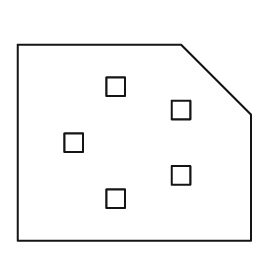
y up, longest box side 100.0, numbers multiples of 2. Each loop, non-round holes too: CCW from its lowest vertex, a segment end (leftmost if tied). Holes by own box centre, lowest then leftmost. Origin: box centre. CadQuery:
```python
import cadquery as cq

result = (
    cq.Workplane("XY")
    .moveTo(-50.0, -42.0)
    .lineTo(50.0, -42.0)
    .lineTo(50.0, 12.0)
    .lineTo(20.0, 42.0)
    .lineTo(-50.0, 42.0)
    .close()
    .moveTo(-12.0, -28.0)
    .lineTo(-4.0, -28.0)
    .lineTo(-4.0, -20.0)
    .lineTo(-12.0, -20.0)
    .close()
    .moveTo(16.0, -18.0)
    .lineTo(24.0, -18.0)
    .lineTo(24.0, -10.0)
    .lineTo(16.0, -10.0)
    .close()
    .moveTo(-30.0, -4.0)
    .lineTo(-22.0, -4.0)
    .lineTo(-22.0, 4.0)
    .lineTo(-30.0, 4.0)
    .close()
    .moveTo(16.0, 10.0)
    .lineTo(24.0, 10.0)
    .lineTo(24.0, 18.0)
    .lineTo(16.0, 18.0)
    .close()
    .moveTo(-12.0, 20.0)
    .lineTo(-4.0, 20.0)
    .lineTo(-4.0, 28.0)
    .lineTo(-12.0, 28.0)
    .close()
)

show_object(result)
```